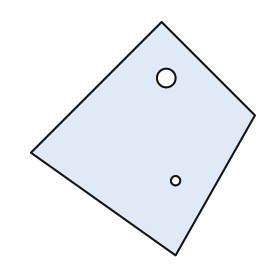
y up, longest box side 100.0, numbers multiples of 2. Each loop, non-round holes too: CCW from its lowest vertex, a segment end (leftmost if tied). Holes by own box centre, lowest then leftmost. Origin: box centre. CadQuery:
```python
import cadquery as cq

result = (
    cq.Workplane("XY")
    .moveTo(14.0, -50.0)
    .lineTo(48.0, 10.0)
    .lineTo(8.0, 50.0)
    .lineTo(-48.0, -6.0)
    .close()
    .moveTo(14.0, -18.0)
    .circle(2.0)
    .moveTo(10.0, 26.0)
    .circle(4.0)
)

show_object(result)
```